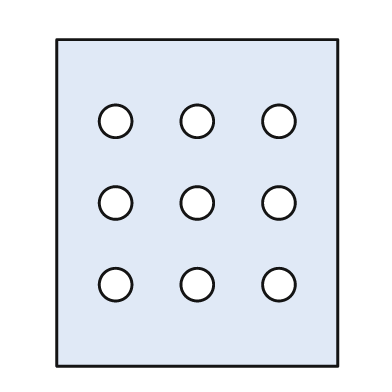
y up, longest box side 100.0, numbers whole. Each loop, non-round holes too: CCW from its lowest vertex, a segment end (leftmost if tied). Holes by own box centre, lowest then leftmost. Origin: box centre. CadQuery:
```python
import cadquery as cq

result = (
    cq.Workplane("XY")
    .moveTo(-43.0, -50.0)
    .lineTo(43.0, -50.0)
    .lineTo(43.0, 50.0)
    .lineTo(-43.0, 50.0)
    .close()
    .moveTo(-25.0, -25.0)
    .circle(5.0)
    .moveTo(0.0, -25.0)
    .circle(5.0)
    .moveTo(25.0, -25.0)
    .circle(5.0)
    .moveTo(-25.0, 0.0)
    .circle(5.0)
    .moveTo(0.0, 0.0)
    .circle(5.0)
    .moveTo(25.0, 0.0)
    .circle(5.0)
    .moveTo(-25.0, 25.0)
    .circle(5.0)
    .moveTo(0.0, 25.0)
    .circle(5.0)
    .moveTo(25.0, 25.0)
    .circle(5.0)
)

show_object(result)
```